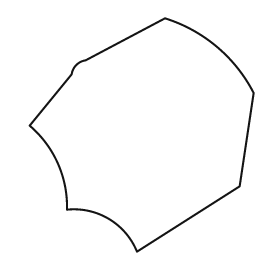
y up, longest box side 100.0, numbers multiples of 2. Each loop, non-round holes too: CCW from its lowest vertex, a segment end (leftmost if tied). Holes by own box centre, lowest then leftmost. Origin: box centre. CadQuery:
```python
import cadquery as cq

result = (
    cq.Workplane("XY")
    .moveTo(-2.0, -50.0)
    .lineTo(42.0, -22.0)
    .lineTo(48.0, 18.0)
    .threePointArc((32.0, 38.0), (10.0, 50.0))
    .lineTo(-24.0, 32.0)
    .threePointArc((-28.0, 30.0), (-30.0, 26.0))
    .lineTo(-48.0, 4.0)
    .threePointArc((-36.0, -12.0), (-32.0, -32.0))
    .threePointArc((-14.0, -36.0), (-2.0, -50.0))
    .close()
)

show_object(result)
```